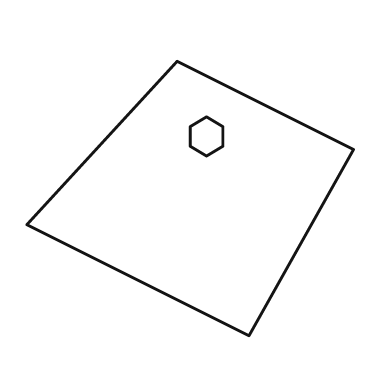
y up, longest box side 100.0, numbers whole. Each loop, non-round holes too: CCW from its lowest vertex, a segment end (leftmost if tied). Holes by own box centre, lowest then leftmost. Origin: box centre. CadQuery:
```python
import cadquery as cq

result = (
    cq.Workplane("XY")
    .moveTo(18.0, -42.0)
    .lineTo(50.0, 15.0)
    .lineTo(-4.0, 42.0)
    .lineTo(-50.0, -8.0)
    .close()
    .moveTo(5.0, 13.0)
    .lineTo(10.0, 16.0)
    .lineTo(10.0, 22.0)
    .lineTo(5.0, 25.0)
    .lineTo(0.0, 22.0)
    .lineTo(0.0, 16.0)
    .close()
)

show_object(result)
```